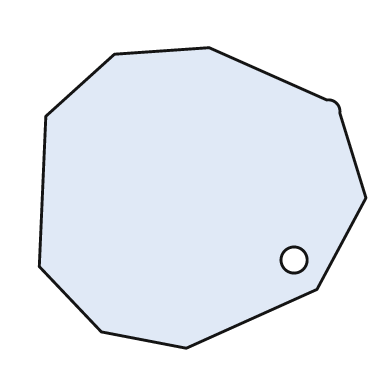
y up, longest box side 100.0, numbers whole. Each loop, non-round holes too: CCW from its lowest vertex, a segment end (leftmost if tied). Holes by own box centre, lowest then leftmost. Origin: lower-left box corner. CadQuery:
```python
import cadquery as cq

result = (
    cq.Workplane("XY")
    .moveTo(45.0, 0.0)
    .lineTo(85.0, 18.0)
    .lineTo(100.0, 46.0)
    .lineTo(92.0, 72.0)
    .threePointArc((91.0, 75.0), (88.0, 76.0))
    .lineTo(52.0, 92.0)
    .lineTo(23.0, 90.0)
    .lineTo(2.0, 71.0)
    .lineTo(0.0, 25.0)
    .lineTo(19.0, 5.0)
    .close()
    .moveTo(78.0, 27.0)
    .circle(4.0)
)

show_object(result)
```